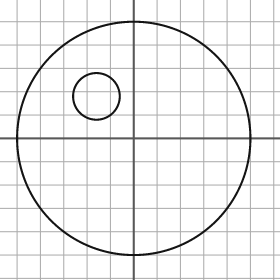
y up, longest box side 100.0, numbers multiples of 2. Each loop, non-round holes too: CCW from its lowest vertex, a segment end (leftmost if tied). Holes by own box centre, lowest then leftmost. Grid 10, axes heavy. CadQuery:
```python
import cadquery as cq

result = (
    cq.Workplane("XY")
    .moveTo(0.0, 0.0)
    .circle(50.0)
    .moveTo(-16.0, 18.0)
    .circle(10.0)
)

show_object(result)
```